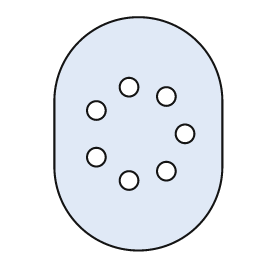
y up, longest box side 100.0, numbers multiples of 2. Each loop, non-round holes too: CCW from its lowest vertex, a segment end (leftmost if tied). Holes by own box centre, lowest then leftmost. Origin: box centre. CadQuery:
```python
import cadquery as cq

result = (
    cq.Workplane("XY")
    .moveTo(-36.0, -14.0)
    .threePointArc((0.0, -50.0), (36.0, -14.0))
    .lineTo(36.0, 14.0)
    .threePointArc((0.0, 50.0), (-36.0, 14.0))
    .close()
    .moveTo(-4.0, -20.0)
    .circle(4.0)
    .moveTo(12.0, -16.0)
    .circle(4.0)
    .moveTo(-18.0, -10.0)
    .circle(4.0)
    .moveTo(20.0, 0.0)
    .circle(4.0)
    .moveTo(-18.0, 10.0)
    .circle(4.0)
    .moveTo(12.0, 16.0)
    .circle(4.0)
    .moveTo(-4.0, 20.0)
    .circle(4.0)
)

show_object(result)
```